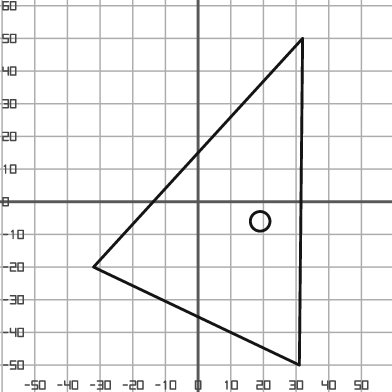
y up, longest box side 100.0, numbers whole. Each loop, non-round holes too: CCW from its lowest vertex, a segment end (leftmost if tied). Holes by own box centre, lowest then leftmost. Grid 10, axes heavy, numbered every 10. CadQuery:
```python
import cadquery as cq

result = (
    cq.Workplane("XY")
    .moveTo(31.0, -50.0)
    .lineTo(32.0, 50.0)
    .lineTo(-32.0, -20.0)
    .close()
    .moveTo(19.0, -6.0)
    .circle(3.0)
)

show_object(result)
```